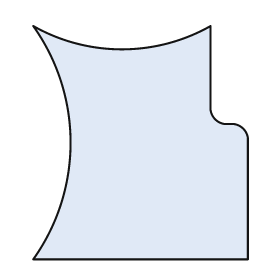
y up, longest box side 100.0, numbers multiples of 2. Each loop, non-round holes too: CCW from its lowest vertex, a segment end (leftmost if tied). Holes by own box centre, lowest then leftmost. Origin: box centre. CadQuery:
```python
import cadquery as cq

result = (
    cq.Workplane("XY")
    .moveTo(-46.0, -50.0)
    .lineTo(46.0, -50.0)
    .lineTo(46.0, 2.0)
    .threePointArc((44.0, 6.0), (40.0, 8.0))
    .lineTo(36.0, 8.0)
    .threePointArc((32.0, 10.0), (30.0, 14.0))
    .lineTo(30.0, 50.0)
    .threePointArc((-8.0, 40.0), (-46.0, 50.0))
    .threePointArc((-30.0, 0.0), (-46.0, -50.0))
    .close()
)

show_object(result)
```